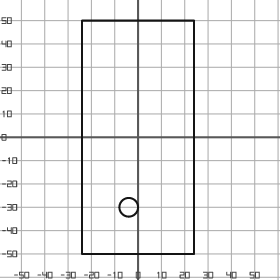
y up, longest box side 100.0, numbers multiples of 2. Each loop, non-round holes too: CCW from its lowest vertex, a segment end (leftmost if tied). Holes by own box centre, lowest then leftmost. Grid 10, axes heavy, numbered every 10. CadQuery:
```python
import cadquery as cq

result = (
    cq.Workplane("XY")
    .moveTo(-24.0, -50.0)
    .lineTo(24.0, -50.0)
    .lineTo(24.0, 50.0)
    .lineTo(-24.0, 50.0)
    .close()
    .moveTo(-4.0, -30.0)
    .circle(4.0)
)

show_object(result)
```